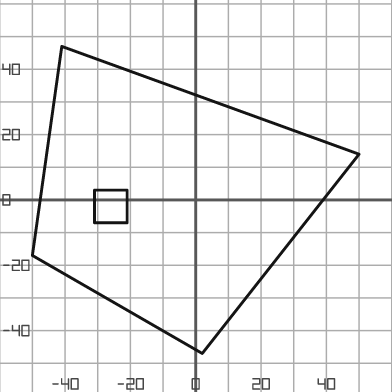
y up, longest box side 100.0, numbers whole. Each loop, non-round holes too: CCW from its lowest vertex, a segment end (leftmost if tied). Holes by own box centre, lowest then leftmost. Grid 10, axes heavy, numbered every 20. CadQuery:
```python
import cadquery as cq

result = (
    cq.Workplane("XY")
    .moveTo(2.0, -47.0)
    .lineTo(50.0, 14.0)
    .lineTo(-41.0, 47.0)
    .lineTo(-50.0, -17.0)
    .close()
    .moveTo(-31.0, -7.0)
    .lineTo(-21.0, -7.0)
    .lineTo(-21.0, 3.0)
    .lineTo(-31.0, 3.0)
    .close()
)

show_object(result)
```